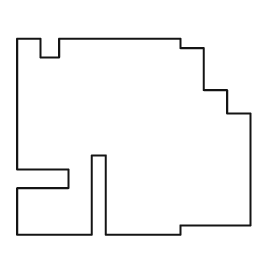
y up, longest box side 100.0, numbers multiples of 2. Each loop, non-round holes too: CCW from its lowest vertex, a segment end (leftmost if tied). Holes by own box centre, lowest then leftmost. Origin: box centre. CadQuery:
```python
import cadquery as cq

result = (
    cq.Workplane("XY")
    .moveTo(-50.0, -42.0)
    .lineTo(-18.0, -42.0)
    .lineTo(-18.0, -8.0)
    .lineTo(-12.0, -8.0)
    .lineTo(-12.0, -42.0)
    .lineTo(20.0, -42.0)
    .lineTo(20.0, -38.0)
    .lineTo(50.0, -38.0)
    .lineTo(50.0, 10.0)
    .lineTo(40.0, 10.0)
    .lineTo(40.0, 20.0)
    .lineTo(30.0, 20.0)
    .lineTo(30.0, 38.0)
    .lineTo(20.0, 38.0)
    .lineTo(20.0, 42.0)
    .lineTo(-32.0, 42.0)
    .lineTo(-32.0, 34.0)
    .lineTo(-40.0, 34.0)
    .lineTo(-40.0, 42.0)
    .lineTo(-50.0, 42.0)
    .lineTo(-50.0, -14.0)
    .lineTo(-28.0, -14.0)
    .lineTo(-28.0, -22.0)
    .lineTo(-50.0, -22.0)
    .close()
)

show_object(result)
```